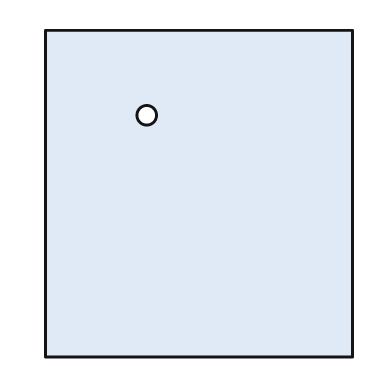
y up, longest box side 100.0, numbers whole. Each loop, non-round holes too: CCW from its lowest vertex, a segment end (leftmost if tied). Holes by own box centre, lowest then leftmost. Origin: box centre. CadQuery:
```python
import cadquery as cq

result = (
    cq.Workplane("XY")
    .moveTo(-47.0, -50.0)
    .lineTo(47.0, -50.0)
    .lineTo(47.0, 50.0)
    .lineTo(-47.0, 50.0)
    .close()
    .moveTo(-16.0, 24.0)
    .circle(3.0)
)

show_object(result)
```